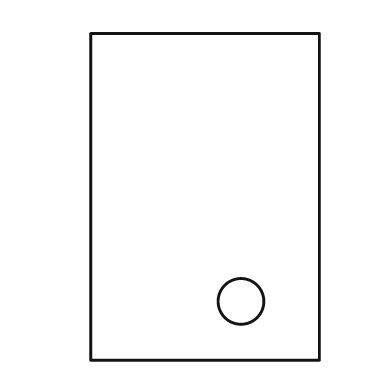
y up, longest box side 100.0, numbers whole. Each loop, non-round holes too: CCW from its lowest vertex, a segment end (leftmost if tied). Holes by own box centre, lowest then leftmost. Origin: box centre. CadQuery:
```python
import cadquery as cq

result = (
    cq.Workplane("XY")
    .moveTo(-35.0, -50.0)
    .lineTo(35.0, -50.0)
    .lineTo(35.0, 50.0)
    .lineTo(-35.0, 50.0)
    .close()
    .moveTo(11.0, -32.0)
    .circle(7.0)
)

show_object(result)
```